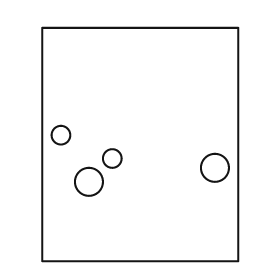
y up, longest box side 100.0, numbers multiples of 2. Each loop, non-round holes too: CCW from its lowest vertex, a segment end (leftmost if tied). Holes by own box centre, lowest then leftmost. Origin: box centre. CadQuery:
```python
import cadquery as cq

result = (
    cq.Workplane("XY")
    .moveTo(-42.0, -50.0)
    .lineTo(42.0, -50.0)
    .lineTo(42.0, 50.0)
    .lineTo(-42.0, 50.0)
    .close()
    .moveTo(-22.0, -16.0)
    .circle(6.0)
    .moveTo(32.0, -10.0)
    .circle(6.0)
    .moveTo(-12.0, -6.0)
    .circle(4.0)
    .moveTo(-34.0, 4.0)
    .circle(4.0)
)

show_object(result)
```